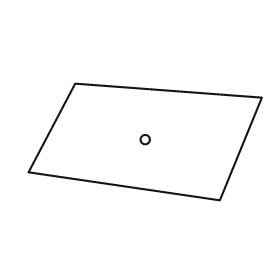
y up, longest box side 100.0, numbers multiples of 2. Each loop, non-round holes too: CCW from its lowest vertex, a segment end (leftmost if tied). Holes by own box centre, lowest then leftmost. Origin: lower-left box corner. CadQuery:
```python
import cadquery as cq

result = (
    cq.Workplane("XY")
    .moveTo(82.0, 0.0)
    .lineTo(100.0, 44.0)
    .lineTo(20.0, 50.0)
    .lineTo(0.0, 12.0)
    .close()
    .moveTo(50.0, 26.0)
    .circle(2.0)
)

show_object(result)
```